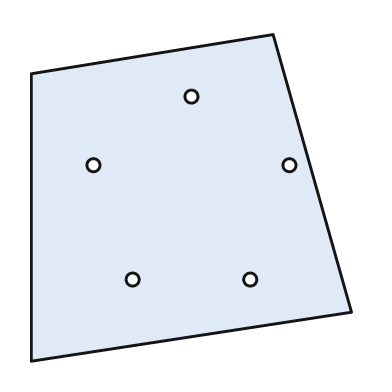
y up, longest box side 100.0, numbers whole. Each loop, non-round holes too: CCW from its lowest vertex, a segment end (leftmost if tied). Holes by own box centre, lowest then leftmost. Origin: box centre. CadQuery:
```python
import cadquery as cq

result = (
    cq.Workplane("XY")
    .moveTo(-49.0, -50.0)
    .lineTo(49.0, -35.0)
    .lineTo(25.0, 50.0)
    .lineTo(-49.0, 38.0)
    .close()
    .moveTo(-18.0, -25.0)
    .circle(2.0)
    .moveTo(18.0, -25.0)
    .circle(2.0)
    .moveTo(-30.0, 10.0)
    .circle(2.0)
    .moveTo(30.0, 10.0)
    .circle(2.0)
    .moveTo(0.0, 31.0)
    .circle(2.0)
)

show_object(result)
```